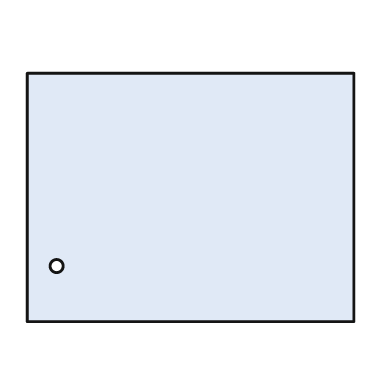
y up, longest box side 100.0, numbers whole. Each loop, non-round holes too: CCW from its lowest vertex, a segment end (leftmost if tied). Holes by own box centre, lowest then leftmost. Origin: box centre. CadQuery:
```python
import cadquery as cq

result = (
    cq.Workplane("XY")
    .moveTo(-50.0, -38.0)
    .lineTo(50.0, -38.0)
    .lineTo(50.0, 38.0)
    .lineTo(-50.0, 38.0)
    .close()
    .moveTo(-41.0, -21.0)
    .circle(2.0)
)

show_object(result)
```